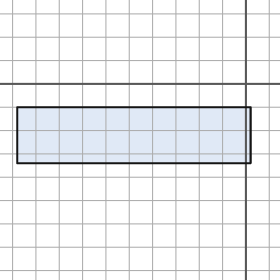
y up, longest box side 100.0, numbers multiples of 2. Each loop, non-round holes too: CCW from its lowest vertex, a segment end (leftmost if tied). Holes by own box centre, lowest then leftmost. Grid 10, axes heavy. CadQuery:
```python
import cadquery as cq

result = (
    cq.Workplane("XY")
    .moveTo(-98.0, -34.0)
    .lineTo(2.0, -34.0)
    .lineTo(2.0, -10.0)
    .lineTo(-98.0, -10.0)
    .close()
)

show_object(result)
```